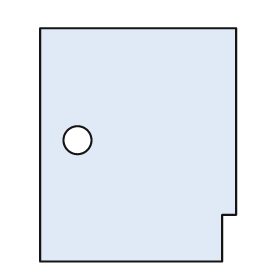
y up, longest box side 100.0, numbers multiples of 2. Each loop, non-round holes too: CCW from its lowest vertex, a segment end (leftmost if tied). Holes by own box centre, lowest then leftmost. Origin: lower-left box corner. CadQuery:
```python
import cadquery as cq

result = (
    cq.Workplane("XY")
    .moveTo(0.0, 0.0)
    .lineTo(78.0, 0.0)
    .lineTo(78.0, 20.0)
    .lineTo(84.0, 20.0)
    .lineTo(84.0, 100.0)
    .lineTo(0.0, 100.0)
    .close()
    .moveTo(16.0, 52.0)
    .circle(6.0)
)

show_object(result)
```